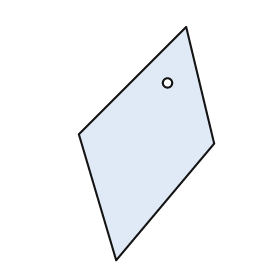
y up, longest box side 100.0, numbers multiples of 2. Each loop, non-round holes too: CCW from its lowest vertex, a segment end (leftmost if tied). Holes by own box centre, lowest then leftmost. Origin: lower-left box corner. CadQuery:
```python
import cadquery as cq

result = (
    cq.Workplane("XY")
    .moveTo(16.0, 0.0)
    .lineTo(58.0, 50.0)
    .lineTo(46.0, 100.0)
    .lineTo(0.0, 54.0)
    .close()
    .moveTo(38.0, 76.0)
    .circle(2.0)
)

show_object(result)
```